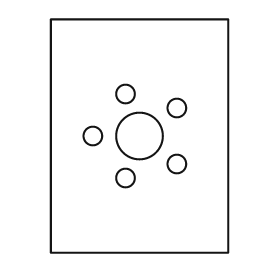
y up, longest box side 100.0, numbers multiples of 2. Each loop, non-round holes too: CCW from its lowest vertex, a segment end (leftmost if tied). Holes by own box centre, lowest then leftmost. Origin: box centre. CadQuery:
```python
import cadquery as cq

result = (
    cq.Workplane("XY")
    .moveTo(-38.0, -50.0)
    .lineTo(38.0, -50.0)
    .lineTo(38.0, 50.0)
    .lineTo(-38.0, 50.0)
    .close()
    .moveTo(-6.0, -18.0)
    .circle(4.0)
    .moveTo(16.0, -12.0)
    .circle(4.0)
    .moveTo(-20.0, 0.0)
    .circle(4.0)
    .moveTo(0.0, 0.0)
    .circle(10.0)
    .moveTo(16.0, 12.0)
    .circle(4.0)
    .moveTo(-6.0, 18.0)
    .circle(4.0)
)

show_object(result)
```